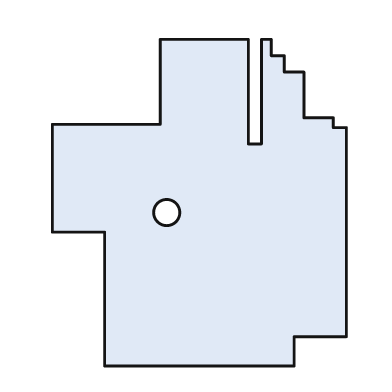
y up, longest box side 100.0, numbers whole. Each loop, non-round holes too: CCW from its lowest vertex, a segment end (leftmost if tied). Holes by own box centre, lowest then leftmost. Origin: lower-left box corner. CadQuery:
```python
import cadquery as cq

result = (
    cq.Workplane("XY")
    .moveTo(16.0, 0.0)
    .lineTo(74.0, 0.0)
    .lineTo(74.0, 9.0)
    .lineTo(90.0, 9.0)
    .lineTo(90.0, 73.0)
    .lineTo(86.0, 73.0)
    .lineTo(86.0, 76.0)
    .lineTo(77.0, 76.0)
    .lineTo(77.0, 90.0)
    .lineTo(71.0, 90.0)
    .lineTo(71.0, 95.0)
    .lineTo(67.0, 95.0)
    .lineTo(67.0, 100.0)
    .lineTo(64.0, 100.0)
    .lineTo(64.0, 68.0)
    .lineTo(60.0, 68.0)
    .lineTo(60.0, 100.0)
    .lineTo(33.0, 100.0)
    .lineTo(33.0, 74.0)
    .lineTo(0.0, 74.0)
    .lineTo(0.0, 41.0)
    .lineTo(16.0, 41.0)
    .close()
    .moveTo(35.0, 47.0)
    .circle(4.0)
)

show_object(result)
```